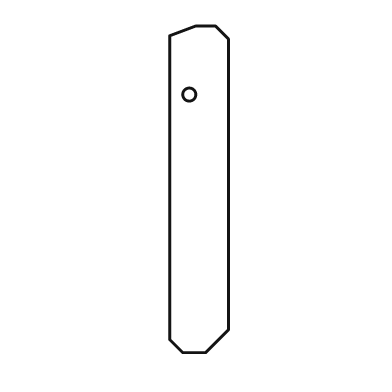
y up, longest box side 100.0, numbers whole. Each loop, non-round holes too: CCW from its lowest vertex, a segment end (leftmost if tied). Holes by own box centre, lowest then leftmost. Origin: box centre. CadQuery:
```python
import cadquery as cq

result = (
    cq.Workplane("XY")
    .moveTo(-5.0, -50.0)
    .lineTo(2.0, -50.0)
    .lineTo(9.0, -43.0)
    .lineTo(9.0, 46.0)
    .lineTo(5.0, 50.0)
    .lineTo(-1.0, 50.0)
    .lineTo(-9.0, 47.0)
    .lineTo(-9.0, -46.0)
    .close()
    .moveTo(-3.0, 29.0)
    .circle(2.0)
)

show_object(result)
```